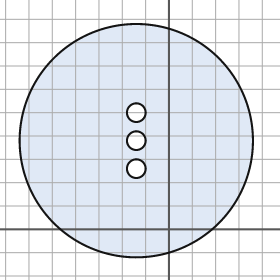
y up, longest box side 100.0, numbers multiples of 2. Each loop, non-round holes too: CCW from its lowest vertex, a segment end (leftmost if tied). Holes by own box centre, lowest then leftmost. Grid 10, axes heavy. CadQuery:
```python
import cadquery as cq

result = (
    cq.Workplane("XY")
    .moveTo(-14.0, 38.0)
    .circle(50.0)
    .moveTo(-14.0, 26.0)
    .circle(4.0)
    .moveTo(-14.0, 38.0)
    .circle(4.0)
    .moveTo(-14.0, 50.0)
    .circle(4.0)
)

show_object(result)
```